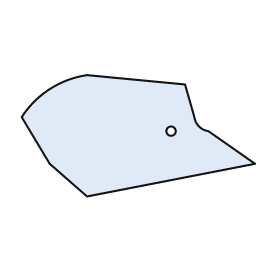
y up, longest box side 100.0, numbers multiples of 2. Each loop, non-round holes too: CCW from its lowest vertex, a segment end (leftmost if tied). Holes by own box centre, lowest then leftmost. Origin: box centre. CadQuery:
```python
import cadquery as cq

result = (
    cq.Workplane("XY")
    .moveTo(-22.0, -26.0)
    .lineTo(50.0, -12.0)
    .lineTo(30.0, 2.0)
    .threePointArc((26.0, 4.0), (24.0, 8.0))
    .lineTo(20.0, 22.0)
    .lineTo(-22.0, 26.0)
    .threePointArc((-38.0, 20.0), (-50.0, 8.0))
    .lineTo(-38.0, -12.0)
    .close()
    .moveTo(14.0, 2.0)
    .circle(2.0)
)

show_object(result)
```